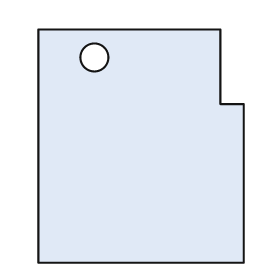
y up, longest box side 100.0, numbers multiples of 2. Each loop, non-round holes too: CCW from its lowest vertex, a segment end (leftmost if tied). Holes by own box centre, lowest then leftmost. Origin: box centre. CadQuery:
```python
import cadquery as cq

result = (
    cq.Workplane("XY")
    .moveTo(-44.0, -50.0)
    .lineTo(44.0, -50.0)
    .lineTo(44.0, 18.0)
    .lineTo(34.0, 18.0)
    .lineTo(34.0, 50.0)
    .lineTo(-44.0, 50.0)
    .close()
    .moveTo(-20.0, 38.0)
    .circle(6.0)
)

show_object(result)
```